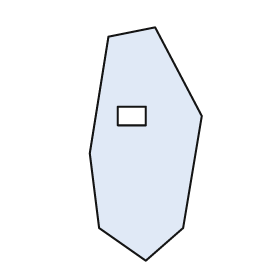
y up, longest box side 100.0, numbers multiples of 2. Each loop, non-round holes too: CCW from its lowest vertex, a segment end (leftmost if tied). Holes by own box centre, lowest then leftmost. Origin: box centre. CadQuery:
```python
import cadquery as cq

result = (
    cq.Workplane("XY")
    .moveTo(0.0, -50.0)
    .lineTo(16.0, -36.0)
    .lineTo(24.0, 12.0)
    .lineTo(4.0, 50.0)
    .lineTo(-16.0, 46.0)
    .lineTo(-24.0, -4.0)
    .lineTo(-20.0, -36.0)
    .close()
    .moveTo(-12.0, 8.0)
    .lineTo(0.0, 8.0)
    .lineTo(0.0, 16.0)
    .lineTo(-12.0, 16.0)
    .close()
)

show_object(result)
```